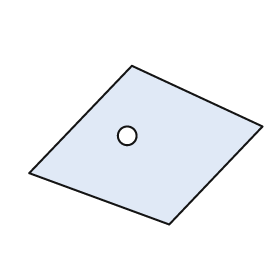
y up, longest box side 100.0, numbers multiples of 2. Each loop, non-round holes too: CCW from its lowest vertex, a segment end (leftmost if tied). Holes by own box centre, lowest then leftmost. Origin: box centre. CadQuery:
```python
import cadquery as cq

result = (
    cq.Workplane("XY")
    .moveTo(10.0, -34.0)
    .lineTo(50.0, 8.0)
    .lineTo(-6.0, 34.0)
    .lineTo(-50.0, -12.0)
    .close()
    .moveTo(-8.0, 4.0)
    .circle(4.0)
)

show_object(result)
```